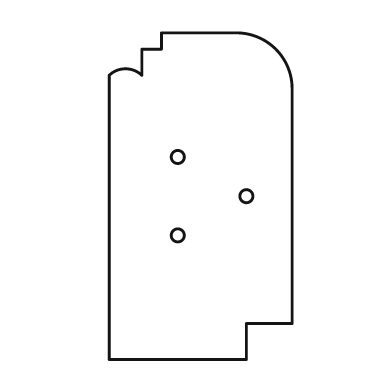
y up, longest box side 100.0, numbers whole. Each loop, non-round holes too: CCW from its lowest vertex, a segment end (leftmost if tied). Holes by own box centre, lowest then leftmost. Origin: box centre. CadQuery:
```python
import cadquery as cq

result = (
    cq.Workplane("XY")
    .moveTo(-28.0, -50.0)
    .lineTo(14.0, -50.0)
    .lineTo(14.0, -39.0)
    .lineTo(28.0, -39.0)
    .lineTo(28.0, 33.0)
    .threePointArc((23.0, 45.0), (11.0, 50.0))
    .lineTo(-12.0, 50.0)
    .lineTo(-12.0, 45.0)
    .lineTo(-18.0, 45.0)
    .lineTo(-18.0, 37.0)
    .threePointArc((-23.0, 39.0), (-28.0, 37.0))
    .close()
    .moveTo(-7.0, -12.0)
    .circle(2.0)
    .moveTo(14.0, 0.0)
    .circle(2.0)
    .moveTo(-7.0, 12.0)
    .circle(2.0)
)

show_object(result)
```